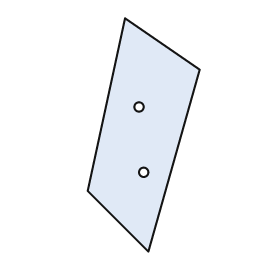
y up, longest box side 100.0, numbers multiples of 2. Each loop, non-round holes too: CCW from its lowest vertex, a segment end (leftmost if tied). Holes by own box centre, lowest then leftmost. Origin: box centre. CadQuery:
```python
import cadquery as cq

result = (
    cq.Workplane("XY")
    .moveTo(2.0, -50.0)
    .lineTo(24.0, 28.0)
    .lineTo(-8.0, 50.0)
    .lineTo(-24.0, -24.0)
    .close()
    .moveTo(0.0, -16.0)
    .circle(2.0)
    .moveTo(-2.0, 12.0)
    .circle(2.0)
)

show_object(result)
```